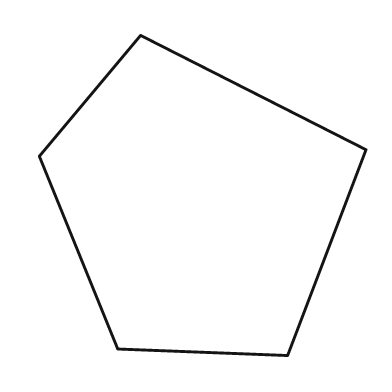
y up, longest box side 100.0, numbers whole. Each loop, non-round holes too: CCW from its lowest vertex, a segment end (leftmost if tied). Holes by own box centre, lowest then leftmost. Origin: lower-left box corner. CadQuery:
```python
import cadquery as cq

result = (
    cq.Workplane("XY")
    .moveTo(76.0, 0.0)
    .lineTo(100.0, 63.0)
    .lineTo(31.0, 98.0)
    .lineTo(0.0, 61.0)
    .lineTo(24.0, 2.0)
    .close()
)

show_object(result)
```